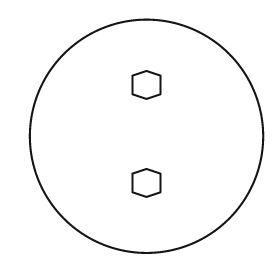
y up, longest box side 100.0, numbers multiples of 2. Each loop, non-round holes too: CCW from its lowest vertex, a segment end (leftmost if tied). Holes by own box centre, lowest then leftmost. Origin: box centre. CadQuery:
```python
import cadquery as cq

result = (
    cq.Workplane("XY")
    .moveTo(0.0, 0.0)
    .circle(50.0)
    .moveTo(0.0, -26.0)
    .lineTo(6.0, -24.0)
    .lineTo(6.0, -16.0)
    .lineTo(0.0, -14.0)
    .lineTo(-6.0, -16.0)
    .lineTo(-6.0, -24.0)
    .close()
    .moveTo(0.0, 16.0)
    .lineTo(6.0, 18.0)
    .lineTo(6.0, 26.0)
    .lineTo(0.0, 28.0)
    .lineTo(-6.0, 26.0)
    .lineTo(-6.0, 18.0)
    .close()
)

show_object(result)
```